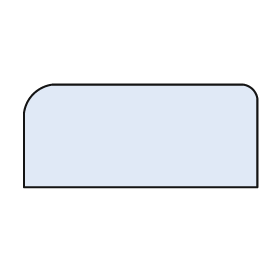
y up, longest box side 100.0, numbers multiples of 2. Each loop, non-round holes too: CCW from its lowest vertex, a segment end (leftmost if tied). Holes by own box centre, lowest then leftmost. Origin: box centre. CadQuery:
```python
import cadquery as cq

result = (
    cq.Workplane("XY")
    .moveTo(-50.0, -22.0)
    .lineTo(50.0, -22.0)
    .lineTo(50.0, 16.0)
    .threePointArc((48.0, 20.0), (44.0, 22.0))
    .lineTo(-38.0, 22.0)
    .threePointArc((-46.0, 18.0), (-50.0, 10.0))
    .close()
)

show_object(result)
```